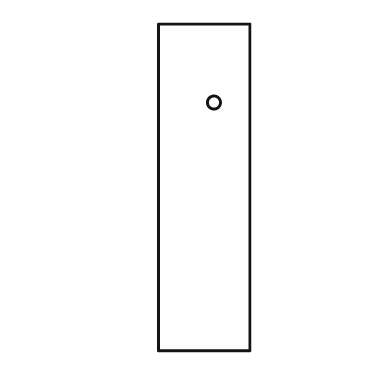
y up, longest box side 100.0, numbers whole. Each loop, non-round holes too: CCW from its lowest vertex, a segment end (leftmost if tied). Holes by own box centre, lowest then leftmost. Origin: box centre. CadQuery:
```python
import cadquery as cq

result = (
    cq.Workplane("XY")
    .moveTo(-14.0, -50.0)
    .lineTo(14.0, -50.0)
    .lineTo(14.0, 50.0)
    .lineTo(-14.0, 50.0)
    .close()
    .moveTo(3.0, 26.0)
    .circle(2.0)
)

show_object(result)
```